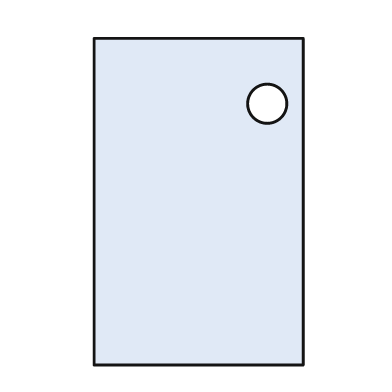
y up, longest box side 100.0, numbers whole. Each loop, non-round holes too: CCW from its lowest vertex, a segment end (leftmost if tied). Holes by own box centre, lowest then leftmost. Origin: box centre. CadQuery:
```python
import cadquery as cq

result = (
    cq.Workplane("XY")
    .moveTo(-32.0, -50.0)
    .lineTo(32.0, -50.0)
    .lineTo(32.0, 50.0)
    .lineTo(-32.0, 50.0)
    .close()
    .moveTo(21.0, 30.0)
    .circle(6.0)
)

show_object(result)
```